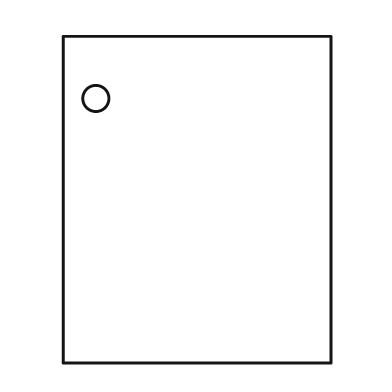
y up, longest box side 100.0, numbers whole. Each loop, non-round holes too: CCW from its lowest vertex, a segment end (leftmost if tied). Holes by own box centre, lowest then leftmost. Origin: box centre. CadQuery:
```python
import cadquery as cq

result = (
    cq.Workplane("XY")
    .moveTo(-41.0, -50.0)
    .lineTo(41.0, -50.0)
    .lineTo(41.0, 50.0)
    .lineTo(-41.0, 50.0)
    .close()
    .moveTo(-31.0, 31.0)
    .circle(4.0)
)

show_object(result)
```